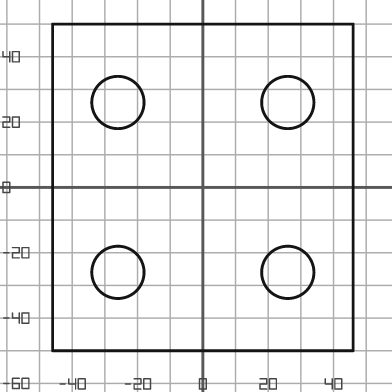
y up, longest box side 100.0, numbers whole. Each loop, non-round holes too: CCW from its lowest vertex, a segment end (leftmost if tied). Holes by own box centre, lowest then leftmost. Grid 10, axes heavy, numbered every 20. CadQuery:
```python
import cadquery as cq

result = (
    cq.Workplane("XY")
    .moveTo(-46.0, -50.0)
    .lineTo(46.0, -50.0)
    .lineTo(46.0, 50.0)
    .lineTo(-46.0, 50.0)
    .close()
    .moveTo(-26.0, -26.0)
    .circle(8.0)
    .moveTo(26.0, -26.0)
    .circle(8.0)
    .moveTo(-26.0, 26.0)
    .circle(8.0)
    .moveTo(26.0, 26.0)
    .circle(8.0)
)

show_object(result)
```